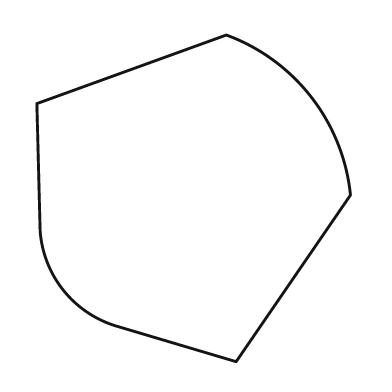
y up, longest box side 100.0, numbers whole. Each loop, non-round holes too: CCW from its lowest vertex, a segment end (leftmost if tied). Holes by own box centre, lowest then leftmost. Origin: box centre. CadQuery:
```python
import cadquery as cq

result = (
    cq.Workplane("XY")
    .moveTo(13.0, -50.0)
    .lineTo(48.0, 1.0)
    .threePointArc((36.0, 31.0), (10.0, 50.0))
    .lineTo(-48.0, 29.0)
    .lineTo(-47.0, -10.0)
    .threePointArc((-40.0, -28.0), (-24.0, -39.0))
    .close()
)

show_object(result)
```